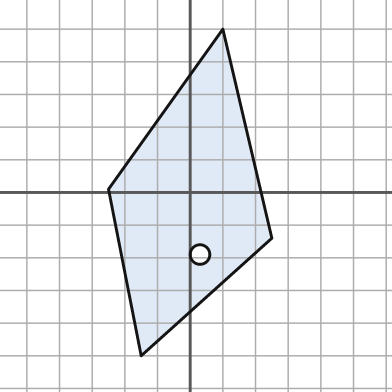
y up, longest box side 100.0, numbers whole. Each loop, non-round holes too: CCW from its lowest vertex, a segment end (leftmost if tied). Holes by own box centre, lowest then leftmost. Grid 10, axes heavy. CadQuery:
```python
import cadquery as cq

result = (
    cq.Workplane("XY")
    .moveTo(-15.0, -50.0)
    .lineTo(25.0, -14.0)
    .lineTo(10.0, 50.0)
    .lineTo(-25.0, 1.0)
    .close()
    .moveTo(3.0, -19.0)
    .circle(3.0)
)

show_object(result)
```